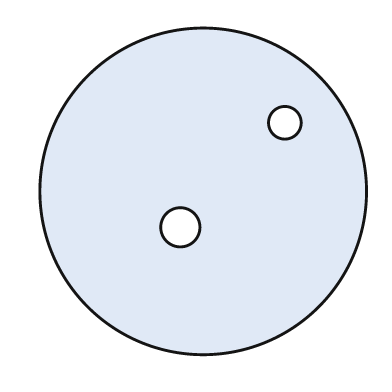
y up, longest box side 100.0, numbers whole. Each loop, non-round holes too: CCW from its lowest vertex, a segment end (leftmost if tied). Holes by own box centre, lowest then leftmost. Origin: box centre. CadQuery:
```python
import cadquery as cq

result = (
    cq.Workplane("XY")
    .moveTo(0.0, 0.0)
    .circle(50.0)
    .moveTo(-7.0, -11.0)
    .circle(6.0)
    .moveTo(25.0, 21.0)
    .circle(5.0)
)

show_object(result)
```